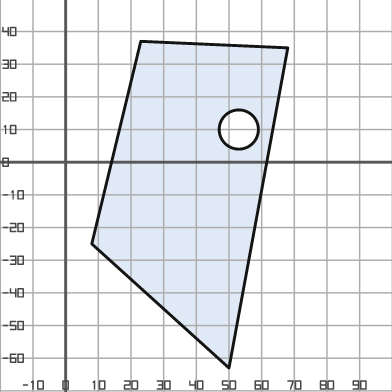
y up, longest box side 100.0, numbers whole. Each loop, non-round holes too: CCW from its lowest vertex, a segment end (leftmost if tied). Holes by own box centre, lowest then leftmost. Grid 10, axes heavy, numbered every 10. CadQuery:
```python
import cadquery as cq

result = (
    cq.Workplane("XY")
    .moveTo(50.0, -63.0)
    .lineTo(68.0, 35.0)
    .lineTo(23.0, 37.0)
    .lineTo(8.0, -25.0)
    .close()
    .moveTo(53.0, 10.0)
    .circle(6.0)
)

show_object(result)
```